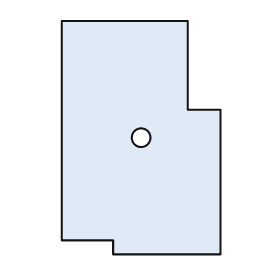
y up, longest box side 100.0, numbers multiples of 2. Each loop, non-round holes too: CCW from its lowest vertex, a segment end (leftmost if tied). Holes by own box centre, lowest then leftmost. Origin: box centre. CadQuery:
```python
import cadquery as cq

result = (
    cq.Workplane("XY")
    .moveTo(-12.0, -50.0)
    .lineTo(34.0, -50.0)
    .lineTo(34.0, 12.0)
    .lineTo(20.0, 12.0)
    .lineTo(20.0, 50.0)
    .lineTo(-34.0, 50.0)
    .lineTo(-34.0, -44.0)
    .lineTo(-12.0, -44.0)
    .close()
    .moveTo(0.0, 0.0)
    .circle(4.0)
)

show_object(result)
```